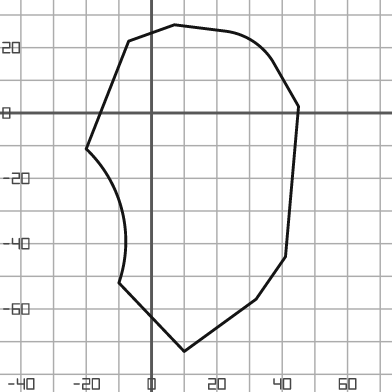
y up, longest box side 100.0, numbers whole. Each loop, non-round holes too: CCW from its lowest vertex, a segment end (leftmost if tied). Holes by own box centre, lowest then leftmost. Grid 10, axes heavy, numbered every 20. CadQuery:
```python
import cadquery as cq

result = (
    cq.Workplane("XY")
    .moveTo(10.0, -73.0)
    .lineTo(32.0, -57.0)
    .lineTo(41.0, -44.0)
    .lineTo(45.0, 2.0)
    .lineTo(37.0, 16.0)
    .threePointArc((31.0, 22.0), (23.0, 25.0))
    .lineTo(7.0, 27.0)
    .lineTo(-7.0, 22.0)
    .lineTo(-20.0, -11.0)
    .threePointArc((-9.0, -30.0), (-10.0, -52.0))
    .close()
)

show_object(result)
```